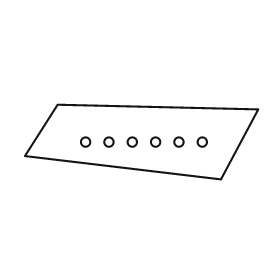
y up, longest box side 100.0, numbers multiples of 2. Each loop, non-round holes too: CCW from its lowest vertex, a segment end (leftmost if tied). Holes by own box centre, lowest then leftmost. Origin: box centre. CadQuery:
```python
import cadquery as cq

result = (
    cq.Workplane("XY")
    .moveTo(34.0, -16.0)
    .lineTo(50.0, 14.0)
    .lineTo(-36.0, 16.0)
    .lineTo(-50.0, -6.0)
    .close()
    .moveTo(-24.0, 0.0)
    .circle(2.0)
    .moveTo(-14.0, 0.0)
    .circle(2.0)
    .moveTo(-4.0, 0.0)
    .circle(2.0)
    .moveTo(6.0, 0.0)
    .circle(2.0)
    .moveTo(16.0, 0.0)
    .circle(2.0)
    .moveTo(26.0, 0.0)
    .circle(2.0)
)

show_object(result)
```